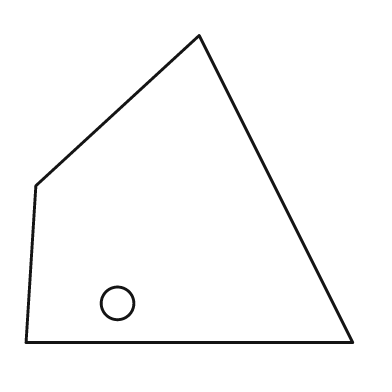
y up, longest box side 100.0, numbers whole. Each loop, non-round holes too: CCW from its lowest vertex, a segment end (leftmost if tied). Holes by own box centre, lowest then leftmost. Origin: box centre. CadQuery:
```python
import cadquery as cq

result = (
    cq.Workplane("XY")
    .moveTo(-50.0, -47.0)
    .lineTo(50.0, -47.0)
    .lineTo(3.0, 47.0)
    .lineTo(-47.0, 1.0)
    .close()
    .moveTo(-22.0, -35.0)
    .circle(5.0)
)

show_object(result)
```